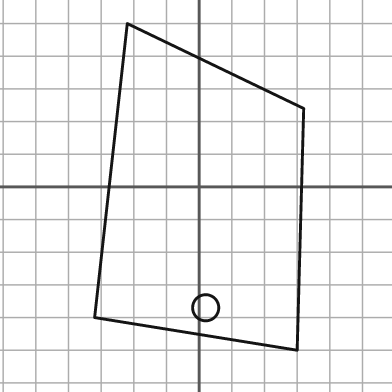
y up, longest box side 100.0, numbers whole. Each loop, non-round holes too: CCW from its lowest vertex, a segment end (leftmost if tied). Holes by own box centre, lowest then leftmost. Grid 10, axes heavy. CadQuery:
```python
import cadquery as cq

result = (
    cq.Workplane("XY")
    .moveTo(30.0, -50.0)
    .lineTo(32.0, 24.0)
    .lineTo(-22.0, 50.0)
    .lineTo(-32.0, -40.0)
    .close()
    .moveTo(2.0, -37.0)
    .circle(4.0)
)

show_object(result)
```